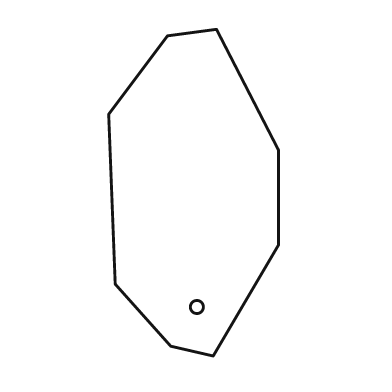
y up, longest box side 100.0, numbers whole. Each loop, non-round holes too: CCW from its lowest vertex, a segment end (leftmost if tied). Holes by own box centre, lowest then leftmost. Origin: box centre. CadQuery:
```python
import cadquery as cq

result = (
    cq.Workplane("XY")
    .moveTo(6.0, -50.0)
    .lineTo(26.0, -16.0)
    .lineTo(26.0, 13.0)
    .lineTo(7.0, 50.0)
    .lineTo(-8.0, 48.0)
    .lineTo(-26.0, 24.0)
    .lineTo(-24.0, -28.0)
    .lineTo(-7.0, -47.0)
    .close()
    .moveTo(1.0, -35.0)
    .circle(2.0)
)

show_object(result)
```